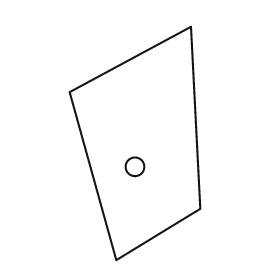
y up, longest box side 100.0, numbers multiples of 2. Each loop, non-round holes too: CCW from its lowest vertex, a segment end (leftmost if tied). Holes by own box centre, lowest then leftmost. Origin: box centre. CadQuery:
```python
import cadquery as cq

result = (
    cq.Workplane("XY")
    .moveTo(-8.0, -50.0)
    .lineTo(28.0, -28.0)
    .lineTo(24.0, 50.0)
    .lineTo(-28.0, 22.0)
    .close()
    .moveTo(0.0, -10.0)
    .circle(4.0)
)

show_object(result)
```